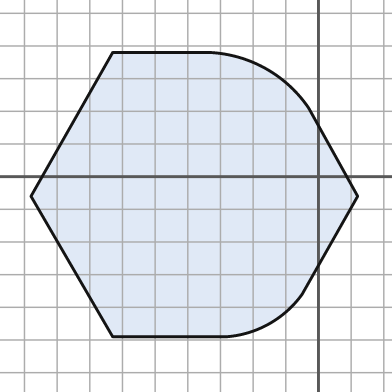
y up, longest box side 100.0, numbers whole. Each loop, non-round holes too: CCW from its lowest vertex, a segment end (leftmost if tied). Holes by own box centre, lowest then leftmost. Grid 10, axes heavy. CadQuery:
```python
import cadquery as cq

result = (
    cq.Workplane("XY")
    .moveTo(-63.0, -49.0)
    .lineTo(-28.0, -49.0)
    .threePointArc((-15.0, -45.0), (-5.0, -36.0))
    .lineTo(12.0, -6.0)
    .lineTo(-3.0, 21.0)
    .threePointArc((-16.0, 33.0), (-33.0, 38.0))
    .lineTo(-63.0, 38.0)
    .lineTo(-88.0, -6.0)
    .close()
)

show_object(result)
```